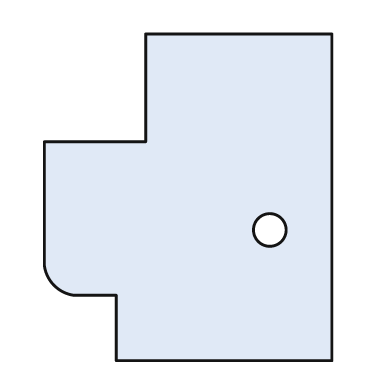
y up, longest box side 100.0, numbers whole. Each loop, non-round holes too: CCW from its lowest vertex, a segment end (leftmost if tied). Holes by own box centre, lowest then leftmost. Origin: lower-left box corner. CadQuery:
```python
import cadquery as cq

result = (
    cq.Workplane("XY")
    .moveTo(22.0, 0.0)
    .lineTo(88.0, 0.0)
    .lineTo(88.0, 100.0)
    .lineTo(31.0, 100.0)
    .lineTo(31.0, 67.0)
    .lineTo(0.0, 67.0)
    .lineTo(0.0, 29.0)
    .threePointArc((3.0, 23.0), (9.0, 20.0))
    .lineTo(22.0, 20.0)
    .close()
    .moveTo(69.0, 40.0)
    .circle(5.0)
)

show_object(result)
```